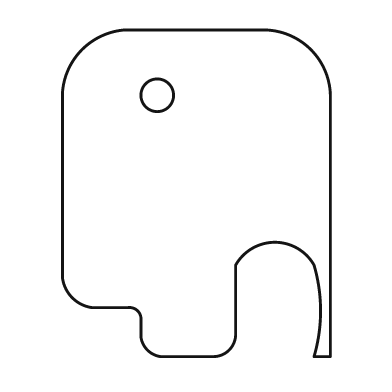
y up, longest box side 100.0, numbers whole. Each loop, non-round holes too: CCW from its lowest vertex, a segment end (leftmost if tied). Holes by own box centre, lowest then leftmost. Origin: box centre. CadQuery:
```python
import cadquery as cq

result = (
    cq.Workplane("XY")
    .moveTo(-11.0, -50.0)
    .lineTo(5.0, -50.0)
    .threePointArc((10.0, -48.0), (12.0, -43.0))
    .lineTo(12.0, -22.0)
    .threePointArc((24.0, -15.0), (36.0, -22.0))
    .threePointArc((38.0, -36.0), (36.0, -50.0))
    .lineTo(41.0, -50.0)
    .lineTo(41.0, 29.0)
    .threePointArc((35.0, 44.0), (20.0, 50.0))
    .lineTo(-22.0, 50.0)
    .threePointArc((-35.0, 44.0), (-41.0, 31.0))
    .lineTo(-41.0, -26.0)
    .threePointArc((-38.0, -32.0), (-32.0, -35.0))
    .lineTo(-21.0, -35.0)
    .threePointArc((-18.0, -36.0), (-17.0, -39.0))
    .lineTo(-17.0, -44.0)
    .threePointArc((-15.0, -48.0), (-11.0, -50.0))
    .close()
    .moveTo(-12.0, 30.0)
    .circle(5.0)
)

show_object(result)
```